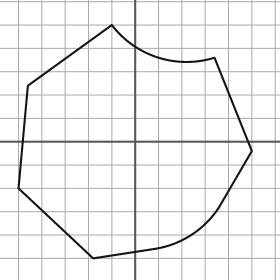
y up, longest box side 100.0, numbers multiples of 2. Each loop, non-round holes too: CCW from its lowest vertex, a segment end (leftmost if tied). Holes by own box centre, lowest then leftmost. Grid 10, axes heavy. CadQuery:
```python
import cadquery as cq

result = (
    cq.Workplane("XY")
    .moveTo(-18.0, -50.0)
    .lineTo(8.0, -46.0)
    .threePointArc((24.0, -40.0), (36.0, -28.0))
    .lineTo(50.0, -4.0)
    .lineTo(34.0, 36.0)
    .threePointArc((10.0, 36.0), (-10.0, 50.0))
    .lineTo(-46.0, 24.0)
    .lineTo(-50.0, -20.0)
    .close()
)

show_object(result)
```